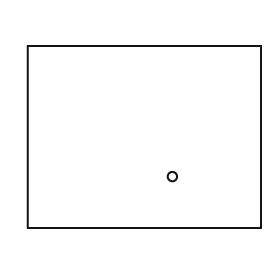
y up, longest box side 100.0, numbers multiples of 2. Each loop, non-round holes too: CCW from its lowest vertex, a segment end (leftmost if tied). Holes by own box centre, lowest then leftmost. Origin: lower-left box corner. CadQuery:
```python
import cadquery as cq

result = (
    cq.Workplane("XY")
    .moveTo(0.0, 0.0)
    .lineTo(100.0, 0.0)
    .lineTo(100.0, 78.0)
    .lineTo(0.0, 78.0)
    .close()
    .moveTo(62.0, 22.0)
    .circle(2.0)
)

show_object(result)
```